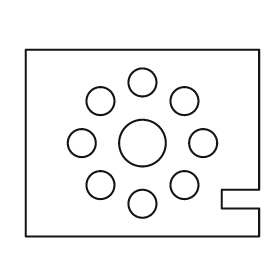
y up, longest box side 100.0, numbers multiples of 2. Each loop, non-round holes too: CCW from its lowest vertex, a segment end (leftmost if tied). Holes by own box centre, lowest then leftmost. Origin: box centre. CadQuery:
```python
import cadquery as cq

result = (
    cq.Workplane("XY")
    .moveTo(-50.0, -40.0)
    .lineTo(50.0, -40.0)
    .lineTo(50.0, -28.0)
    .lineTo(34.0, -28.0)
    .lineTo(34.0, -20.0)
    .lineTo(50.0, -20.0)
    .lineTo(50.0, 40.0)
    .lineTo(-50.0, 40.0)
    .close()
    .moveTo(0.0, -26.0)
    .circle(6.0)
    .moveTo(-18.0, -18.0)
    .circle(6.0)
    .moveTo(18.0, -18.0)
    .circle(6.0)
    .moveTo(-26.0, 0.0)
    .circle(6.0)
    .moveTo(0.0, 0.0)
    .circle(10.0)
    .moveTo(26.0, 0.0)
    .circle(6.0)
    .moveTo(-18.0, 18.0)
    .circle(6.0)
    .moveTo(18.0, 18.0)
    .circle(6.0)
    .moveTo(0.0, 26.0)
    .circle(6.0)
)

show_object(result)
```